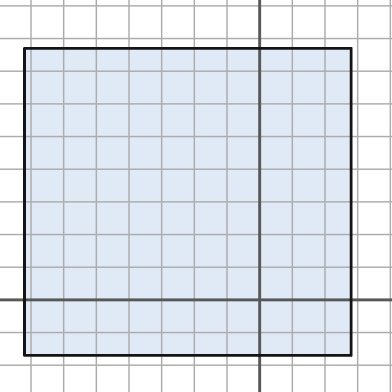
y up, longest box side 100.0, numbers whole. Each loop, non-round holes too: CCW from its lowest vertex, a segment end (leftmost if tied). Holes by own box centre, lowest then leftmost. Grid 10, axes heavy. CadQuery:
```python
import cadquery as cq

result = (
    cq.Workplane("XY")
    .moveTo(-72.0, -17.0)
    .lineTo(28.0, -17.0)
    .lineTo(28.0, 77.0)
    .lineTo(-72.0, 77.0)
    .close()
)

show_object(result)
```